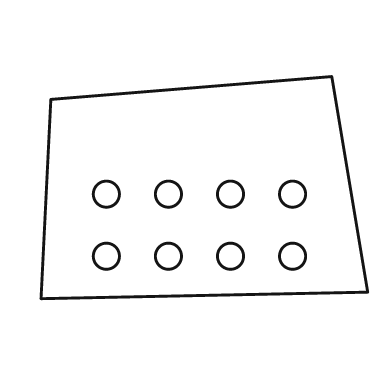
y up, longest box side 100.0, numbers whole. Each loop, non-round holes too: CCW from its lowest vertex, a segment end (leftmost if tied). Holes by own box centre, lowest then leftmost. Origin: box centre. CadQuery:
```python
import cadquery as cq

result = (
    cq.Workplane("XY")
    .moveTo(-50.0, -34.0)
    .lineTo(50.0, -32.0)
    .lineTo(39.0, 34.0)
    .lineTo(-47.0, 27.0)
    .close()
    .moveTo(-30.0, -21.0)
    .circle(4.0)
    .moveTo(-11.0, -21.0)
    .circle(4.0)
    .moveTo(8.0, -21.0)
    .circle(4.0)
    .moveTo(27.0, -21.0)
    .circle(4.0)
    .moveTo(-30.0, -2.0)
    .circle(4.0)
    .moveTo(-11.0, -2.0)
    .circle(4.0)
    .moveTo(8.0, -2.0)
    .circle(4.0)
    .moveTo(27.0, -2.0)
    .circle(4.0)
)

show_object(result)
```